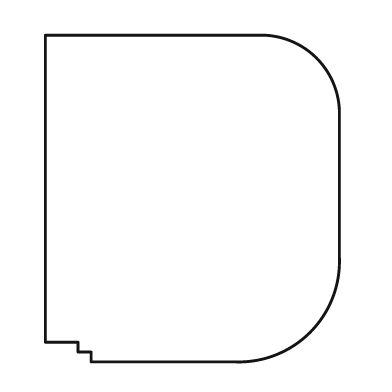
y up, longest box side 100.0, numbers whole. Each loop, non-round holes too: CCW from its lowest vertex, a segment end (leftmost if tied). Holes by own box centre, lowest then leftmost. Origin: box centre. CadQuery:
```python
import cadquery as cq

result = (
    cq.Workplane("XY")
    .moveTo(-31.0, -50.0)
    .lineTo(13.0, -50.0)
    .threePointArc((36.0, -41.0), (45.0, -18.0))
    .lineTo(45.0, 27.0)
    .threePointArc((38.0, 43.0), (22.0, 50.0))
    .lineTo(-45.0, 50.0)
    .lineTo(-45.0, -44.0)
    .lineTo(-35.0, -44.0)
    .lineTo(-35.0, -47.0)
    .lineTo(-31.0, -47.0)
    .close()
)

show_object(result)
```